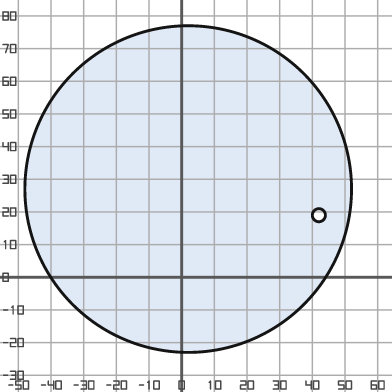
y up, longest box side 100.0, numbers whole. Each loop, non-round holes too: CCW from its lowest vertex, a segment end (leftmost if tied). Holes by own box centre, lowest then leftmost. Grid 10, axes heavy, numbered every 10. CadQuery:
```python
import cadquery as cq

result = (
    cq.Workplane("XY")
    .moveTo(2.0, 27.0)
    .circle(50.0)
    .moveTo(42.0, 19.0)
    .circle(2.0)
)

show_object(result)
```